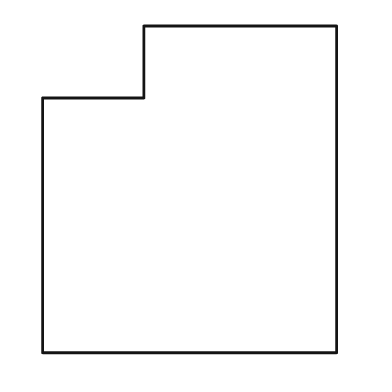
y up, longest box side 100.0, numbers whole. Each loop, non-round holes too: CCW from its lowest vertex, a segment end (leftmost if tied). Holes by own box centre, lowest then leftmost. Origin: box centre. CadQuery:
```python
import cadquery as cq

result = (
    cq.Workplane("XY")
    .moveTo(-45.0, -50.0)
    .lineTo(45.0, -50.0)
    .lineTo(45.0, 50.0)
    .lineTo(-14.0, 50.0)
    .lineTo(-14.0, 28.0)
    .lineTo(-45.0, 28.0)
    .close()
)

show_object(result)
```